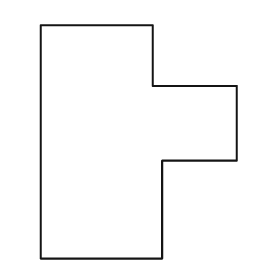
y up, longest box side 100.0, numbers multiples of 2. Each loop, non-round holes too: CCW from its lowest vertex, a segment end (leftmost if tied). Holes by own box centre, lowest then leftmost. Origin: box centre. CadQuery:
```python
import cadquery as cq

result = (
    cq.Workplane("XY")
    .moveTo(-42.0, -50.0)
    .lineTo(10.0, -50.0)
    .lineTo(10.0, -8.0)
    .lineTo(42.0, -8.0)
    .lineTo(42.0, 24.0)
    .lineTo(6.0, 24.0)
    .lineTo(6.0, 50.0)
    .lineTo(-42.0, 50.0)
    .close()
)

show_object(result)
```